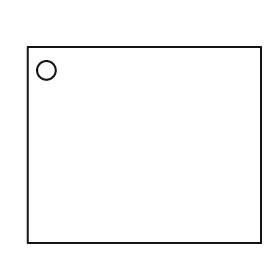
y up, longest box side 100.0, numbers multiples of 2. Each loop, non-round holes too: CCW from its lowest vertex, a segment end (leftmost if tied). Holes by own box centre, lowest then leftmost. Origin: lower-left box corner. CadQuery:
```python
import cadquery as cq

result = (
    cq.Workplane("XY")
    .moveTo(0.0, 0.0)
    .lineTo(100.0, 0.0)
    .lineTo(100.0, 84.0)
    .lineTo(0.0, 84.0)
    .close()
    .moveTo(8.0, 74.0)
    .circle(4.0)
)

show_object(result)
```